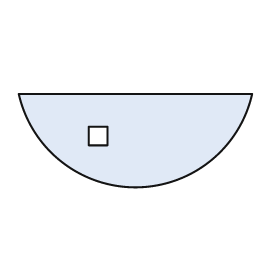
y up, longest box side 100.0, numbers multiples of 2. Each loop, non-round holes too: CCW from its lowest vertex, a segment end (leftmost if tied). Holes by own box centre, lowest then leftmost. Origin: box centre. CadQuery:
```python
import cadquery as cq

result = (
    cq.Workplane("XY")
    .moveTo(-50.0, 20.0)
    .threePointArc((0.0, -20.0), (50.0, 20.0))
    .close()
    .moveTo(-20.0, -2.0)
    .lineTo(-12.0, -2.0)
    .lineTo(-12.0, 6.0)
    .lineTo(-20.0, 6.0)
    .close()
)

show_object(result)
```